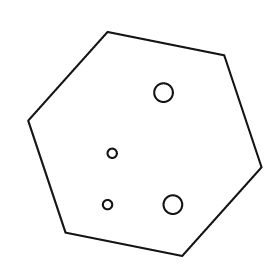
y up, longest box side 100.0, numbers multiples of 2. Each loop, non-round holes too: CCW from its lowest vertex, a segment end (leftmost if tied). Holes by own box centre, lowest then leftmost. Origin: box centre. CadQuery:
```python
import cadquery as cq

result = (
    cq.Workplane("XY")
    .moveTo(16.0, -48.0)
    .lineTo(50.0, -10.0)
    .lineTo(34.0, 38.0)
    .lineTo(-16.0, 48.0)
    .lineTo(-50.0, 10.0)
    .lineTo(-34.0, -38.0)
    .close()
    .moveTo(-16.0, -26.0)
    .circle(2.0)
    .moveTo(12.0, -26.0)
    .circle(4.0)
    .moveTo(-14.0, -4.0)
    .circle(2.0)
    .moveTo(8.0, 22.0)
    .circle(4.0)
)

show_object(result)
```